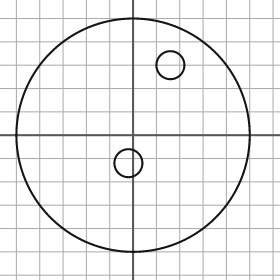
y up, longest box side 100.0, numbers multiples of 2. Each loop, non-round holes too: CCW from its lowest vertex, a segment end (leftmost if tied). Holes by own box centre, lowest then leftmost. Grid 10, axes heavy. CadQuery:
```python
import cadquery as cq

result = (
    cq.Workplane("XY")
    .moveTo(0.0, 0.0)
    .circle(50.0)
    .moveTo(-2.0, -12.0)
    .circle(6.0)
    .moveTo(16.0, 30.0)
    .circle(6.0)
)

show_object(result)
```